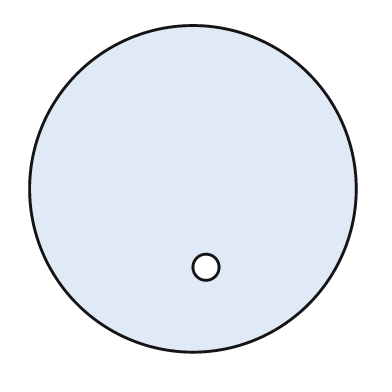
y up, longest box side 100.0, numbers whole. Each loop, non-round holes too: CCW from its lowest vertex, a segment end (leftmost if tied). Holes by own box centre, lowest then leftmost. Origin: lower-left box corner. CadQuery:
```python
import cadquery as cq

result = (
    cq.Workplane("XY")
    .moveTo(50.0, 50.0)
    .circle(50.0)
    .moveTo(54.0, 26.0)
    .circle(4.0)
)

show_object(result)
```